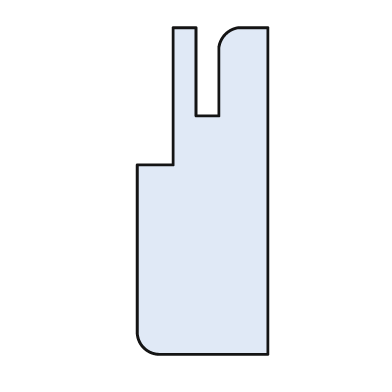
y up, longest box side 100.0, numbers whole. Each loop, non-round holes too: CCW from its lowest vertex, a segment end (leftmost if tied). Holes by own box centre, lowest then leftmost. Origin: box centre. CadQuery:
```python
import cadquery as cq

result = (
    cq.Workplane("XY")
    .moveTo(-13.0, -50.0)
    .lineTo(20.0, -50.0)
    .lineTo(20.0, 50.0)
    .lineTo(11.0, 50.0)
    .threePointArc((7.0, 48.0), (5.0, 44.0))
    .lineTo(5.0, 23.0)
    .lineTo(-2.0, 23.0)
    .lineTo(-2.0, 50.0)
    .lineTo(-9.0, 50.0)
    .lineTo(-9.0, 8.0)
    .lineTo(-20.0, 8.0)
    .lineTo(-20.0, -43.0)
    .threePointArc((-18.0, -48.0), (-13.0, -50.0))
    .close()
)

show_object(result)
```